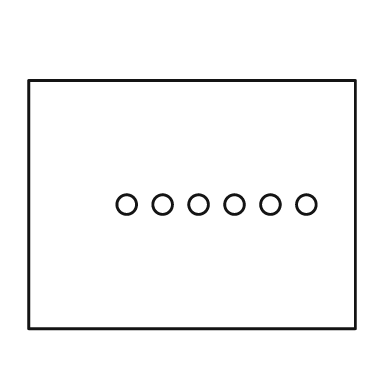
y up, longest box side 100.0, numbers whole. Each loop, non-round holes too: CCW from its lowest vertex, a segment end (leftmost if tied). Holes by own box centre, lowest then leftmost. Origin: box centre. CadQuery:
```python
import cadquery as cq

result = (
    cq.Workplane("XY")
    .moveTo(-50.0, -38.0)
    .lineTo(50.0, -38.0)
    .lineTo(50.0, 38.0)
    .lineTo(-50.0, 38.0)
    .close()
    .moveTo(-20.0, 0.0)
    .circle(3.0)
    .moveTo(-9.0, 0.0)
    .circle(3.0)
    .moveTo(2.0, 0.0)
    .circle(3.0)
    .moveTo(13.0, 0.0)
    .circle(3.0)
    .moveTo(24.0, 0.0)
    .circle(3.0)
    .moveTo(35.0, 0.0)
    .circle(3.0)
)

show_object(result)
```